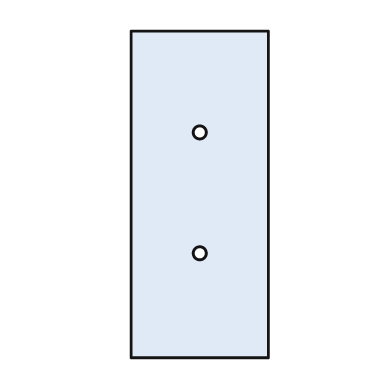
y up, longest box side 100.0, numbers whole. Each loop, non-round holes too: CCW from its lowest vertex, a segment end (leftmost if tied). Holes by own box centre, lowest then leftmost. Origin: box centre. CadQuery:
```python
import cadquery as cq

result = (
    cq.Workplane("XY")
    .moveTo(-21.0, -50.0)
    .lineTo(21.0, -50.0)
    .lineTo(21.0, 50.0)
    .lineTo(-21.0, 50.0)
    .close()
    .moveTo(0.0, -18.0)
    .circle(2.0)
    .moveTo(0.0, 19.0)
    .circle(2.0)
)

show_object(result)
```